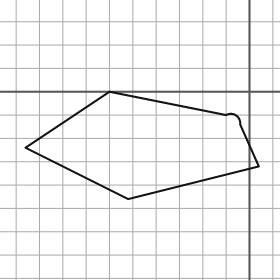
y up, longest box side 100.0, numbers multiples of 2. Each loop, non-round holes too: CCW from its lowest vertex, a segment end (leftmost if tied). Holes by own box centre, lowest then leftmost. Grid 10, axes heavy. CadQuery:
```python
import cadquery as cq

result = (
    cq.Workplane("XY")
    .moveTo(-52.0, -46.0)
    .lineTo(4.0, -32.0)
    .lineTo(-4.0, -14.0)
    .threePointArc((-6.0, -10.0), (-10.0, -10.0))
    .lineTo(-60.0, 0.0)
    .lineTo(-96.0, -24.0)
    .close()
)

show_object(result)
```